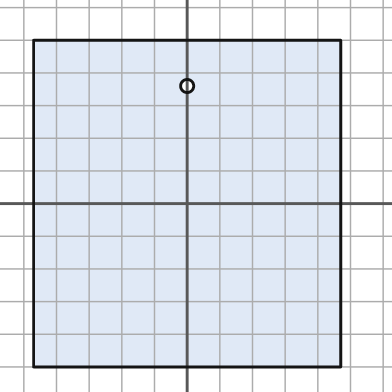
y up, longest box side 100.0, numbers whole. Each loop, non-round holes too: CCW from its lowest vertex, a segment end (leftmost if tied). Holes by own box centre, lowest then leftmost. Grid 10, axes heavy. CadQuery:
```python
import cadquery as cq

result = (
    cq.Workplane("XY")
    .moveTo(-47.0, -50.0)
    .lineTo(47.0, -50.0)
    .lineTo(47.0, 50.0)
    .lineTo(-47.0, 50.0)
    .close()
    .moveTo(0.0, 36.0)
    .circle(2.0)
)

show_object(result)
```